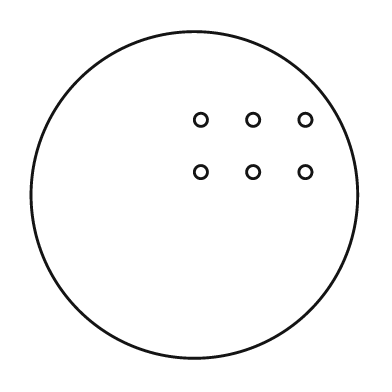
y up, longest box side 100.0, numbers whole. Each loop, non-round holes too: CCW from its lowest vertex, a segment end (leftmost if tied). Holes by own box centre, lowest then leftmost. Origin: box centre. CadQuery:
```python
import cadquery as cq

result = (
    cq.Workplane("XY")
    .moveTo(0.0, 0.0)
    .circle(50.0)
    .moveTo(2.0, 7.0)
    .circle(2.0)
    .moveTo(18.0, 7.0)
    .circle(2.0)
    .moveTo(34.0, 7.0)
    .circle(2.0)
    .moveTo(2.0, 23.0)
    .circle(2.0)
    .moveTo(18.0, 23.0)
    .circle(2.0)
    .moveTo(34.0, 23.0)
    .circle(2.0)
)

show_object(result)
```